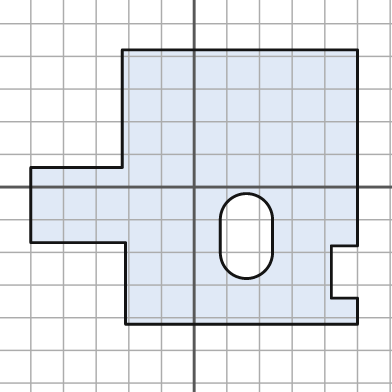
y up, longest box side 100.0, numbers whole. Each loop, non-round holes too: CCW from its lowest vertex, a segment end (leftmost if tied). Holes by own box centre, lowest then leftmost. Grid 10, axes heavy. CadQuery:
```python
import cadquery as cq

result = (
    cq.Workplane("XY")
    .moveTo(-21.0, -42.0)
    .lineTo(50.0, -42.0)
    .lineTo(50.0, -34.0)
    .lineTo(42.0, -34.0)
    .lineTo(42.0, -18.0)
    .lineTo(50.0, -18.0)
    .lineTo(50.0, 42.0)
    .lineTo(-22.0, 42.0)
    .lineTo(-22.0, 6.0)
    .lineTo(-50.0, 6.0)
    .lineTo(-50.0, -17.0)
    .lineTo(-21.0, -17.0)
    .close()
    .moveTo(8.0, -20.0)
    .threePointArc((16.0, -28.0), (24.0, -20.0))
    .lineTo(24.0, -10.0)
    .threePointArc((16.0, -2.0), (8.0, -10.0))
    .close()
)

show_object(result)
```